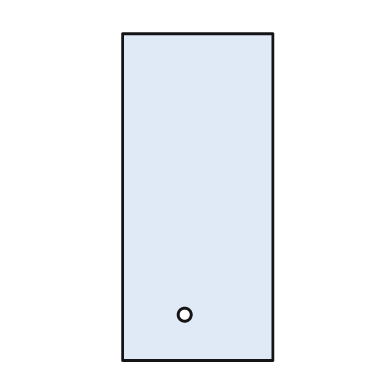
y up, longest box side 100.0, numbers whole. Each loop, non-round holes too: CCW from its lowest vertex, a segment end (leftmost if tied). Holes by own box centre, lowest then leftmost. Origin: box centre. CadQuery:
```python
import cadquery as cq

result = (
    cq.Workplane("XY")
    .moveTo(-23.0, -50.0)
    .lineTo(23.0, -50.0)
    .lineTo(23.0, 50.0)
    .lineTo(-23.0, 50.0)
    .close()
    .moveTo(-4.0, -36.0)
    .circle(2.0)
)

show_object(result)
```